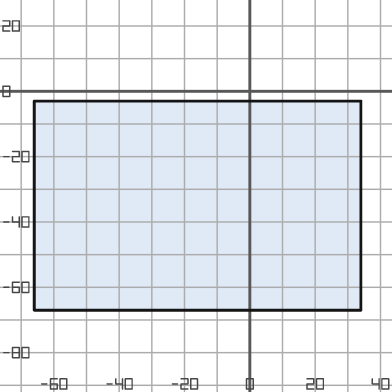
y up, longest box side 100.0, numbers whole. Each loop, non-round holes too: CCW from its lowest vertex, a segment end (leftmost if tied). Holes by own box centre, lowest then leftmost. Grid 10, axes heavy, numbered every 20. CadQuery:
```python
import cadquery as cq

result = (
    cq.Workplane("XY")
    .moveTo(-66.0, -67.0)
    .lineTo(34.0, -67.0)
    .lineTo(34.0, -3.0)
    .lineTo(-66.0, -3.0)
    .close()
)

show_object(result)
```